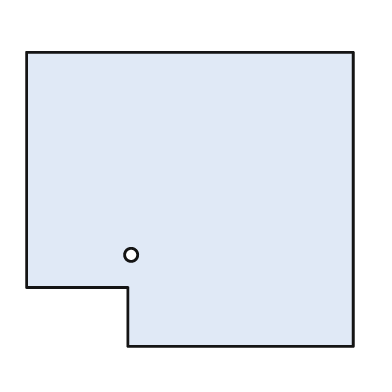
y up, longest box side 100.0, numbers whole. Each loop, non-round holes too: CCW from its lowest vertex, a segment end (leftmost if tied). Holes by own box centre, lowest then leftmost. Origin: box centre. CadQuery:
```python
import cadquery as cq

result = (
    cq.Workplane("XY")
    .moveTo(-19.0, -45.0)
    .lineTo(50.0, -45.0)
    .lineTo(50.0, 45.0)
    .lineTo(-50.0, 45.0)
    .lineTo(-50.0, -27.0)
    .lineTo(-19.0, -27.0)
    .close()
    .moveTo(-18.0, -17.0)
    .circle(2.0)
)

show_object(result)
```